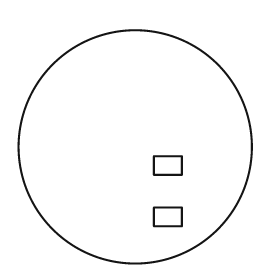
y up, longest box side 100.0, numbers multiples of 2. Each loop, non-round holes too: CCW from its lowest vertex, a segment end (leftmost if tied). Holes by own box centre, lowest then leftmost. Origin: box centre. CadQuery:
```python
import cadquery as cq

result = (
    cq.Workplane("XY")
    .moveTo(0.0, 0.0)
    .circle(50.0)
    .moveTo(8.0, -34.0)
    .lineTo(20.0, -34.0)
    .lineTo(20.0, -26.0)
    .lineTo(8.0, -26.0)
    .close()
    .moveTo(8.0, -12.0)
    .lineTo(20.0, -12.0)
    .lineTo(20.0, -4.0)
    .lineTo(8.0, -4.0)
    .close()
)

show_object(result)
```